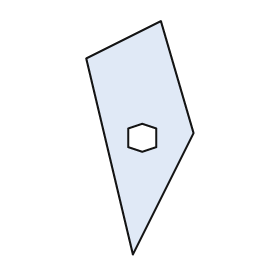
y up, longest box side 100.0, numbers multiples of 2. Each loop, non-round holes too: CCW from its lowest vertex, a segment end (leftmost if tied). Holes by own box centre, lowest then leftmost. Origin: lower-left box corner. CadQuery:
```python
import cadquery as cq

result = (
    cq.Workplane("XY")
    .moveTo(20.0, 0.0)
    .lineTo(46.0, 52.0)
    .lineTo(32.0, 100.0)
    .lineTo(0.0, 84.0)
    .close()
    .moveTo(24.0, 44.0)
    .lineTo(30.0, 46.0)
    .lineTo(30.0, 54.0)
    .lineTo(24.0, 56.0)
    .lineTo(18.0, 54.0)
    .lineTo(18.0, 46.0)
    .close()
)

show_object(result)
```